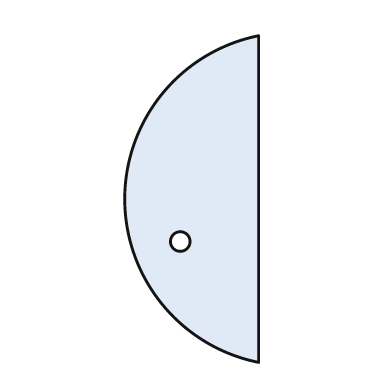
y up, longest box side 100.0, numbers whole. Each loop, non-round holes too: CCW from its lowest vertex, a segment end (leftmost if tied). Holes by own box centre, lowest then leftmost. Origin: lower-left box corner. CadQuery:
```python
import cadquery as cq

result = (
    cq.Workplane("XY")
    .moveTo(41.0, 0.0)
    .lineTo(41.0, 100.0)
    .threePointArc((0.0, 50.0), (41.0, 0.0))
    .close()
    .moveTo(17.0, 37.0)
    .circle(3.0)
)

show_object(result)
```